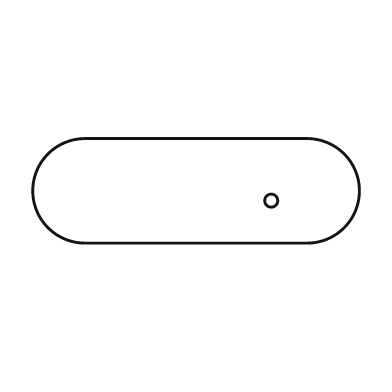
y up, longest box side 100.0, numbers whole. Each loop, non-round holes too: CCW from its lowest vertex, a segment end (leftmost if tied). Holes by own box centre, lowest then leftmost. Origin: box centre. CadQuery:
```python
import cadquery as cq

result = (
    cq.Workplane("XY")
    .moveTo(-34.0, -16.0)
    .lineTo(34.0, -16.0)
    .threePointArc((50.0, 0.0), (34.0, 16.0))
    .lineTo(-34.0, 16.0)
    .threePointArc((-50.0, 0.0), (-34.0, -16.0))
    .close()
    .moveTo(23.0, -3.0)
    .circle(2.0)
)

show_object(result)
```